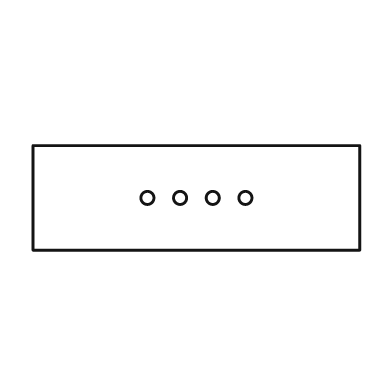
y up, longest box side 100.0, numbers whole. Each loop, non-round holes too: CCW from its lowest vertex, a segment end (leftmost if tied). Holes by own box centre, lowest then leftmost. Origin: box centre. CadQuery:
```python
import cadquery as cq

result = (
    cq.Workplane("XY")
    .moveTo(-50.0, -16.0)
    .lineTo(50.0, -16.0)
    .lineTo(50.0, 16.0)
    .lineTo(-50.0, 16.0)
    .close()
    .moveTo(-15.0, 0.0)
    .circle(2.0)
    .moveTo(-5.0, 0.0)
    .circle(2.0)
    .moveTo(5.0, 0.0)
    .circle(2.0)
    .moveTo(15.0, 0.0)
    .circle(2.0)
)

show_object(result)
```